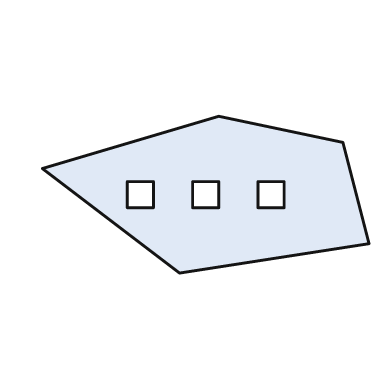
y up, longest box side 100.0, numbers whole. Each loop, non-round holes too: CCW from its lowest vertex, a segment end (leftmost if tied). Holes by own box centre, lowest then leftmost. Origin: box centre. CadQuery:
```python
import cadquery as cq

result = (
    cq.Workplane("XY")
    .moveTo(-8.0, -24.0)
    .lineTo(50.0, -15.0)
    .lineTo(42.0, 16.0)
    .lineTo(4.0, 24.0)
    .lineTo(-50.0, 8.0)
    .close()
    .moveTo(-24.0, -4.0)
    .lineTo(-16.0, -4.0)
    .lineTo(-16.0, 4.0)
    .lineTo(-24.0, 4.0)
    .close()
    .moveTo(-4.0, -4.0)
    .lineTo(4.0, -4.0)
    .lineTo(4.0, 4.0)
    .lineTo(-4.0, 4.0)
    .close()
    .moveTo(16.0, -4.0)
    .lineTo(24.0, -4.0)
    .lineTo(24.0, 4.0)
    .lineTo(16.0, 4.0)
    .close()
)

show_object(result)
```